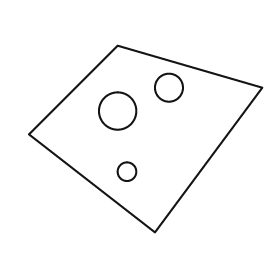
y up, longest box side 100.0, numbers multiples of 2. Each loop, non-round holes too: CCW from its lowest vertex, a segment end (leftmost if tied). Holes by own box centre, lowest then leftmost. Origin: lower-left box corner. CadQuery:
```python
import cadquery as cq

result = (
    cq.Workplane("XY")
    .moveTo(54.0, 0.0)
    .lineTo(100.0, 62.0)
    .lineTo(38.0, 80.0)
    .lineTo(0.0, 42.0)
    .close()
    .moveTo(42.0, 26.0)
    .circle(4.0)
    .moveTo(38.0, 52.0)
    .circle(8.0)
    .moveTo(60.0, 62.0)
    .circle(6.0)
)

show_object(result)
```